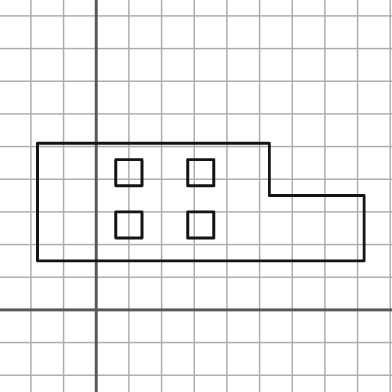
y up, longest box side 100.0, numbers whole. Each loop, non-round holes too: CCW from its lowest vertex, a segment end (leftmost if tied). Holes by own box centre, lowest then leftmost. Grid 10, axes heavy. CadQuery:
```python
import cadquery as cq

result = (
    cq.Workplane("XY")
    .moveTo(-18.0, 15.0)
    .lineTo(82.0, 15.0)
    .lineTo(82.0, 35.0)
    .lineTo(53.0, 35.0)
    .lineTo(53.0, 51.0)
    .lineTo(-18.0, 51.0)
    .close()
    .moveTo(6.0, 22.0)
    .lineTo(14.0, 22.0)
    .lineTo(14.0, 30.0)
    .lineTo(6.0, 30.0)
    .close()
    .moveTo(28.0, 22.0)
    .lineTo(36.0, 22.0)
    .lineTo(36.0, 30.0)
    .lineTo(28.0, 30.0)
    .close()
    .moveTo(6.0, 38.0)
    .lineTo(14.0, 38.0)
    .lineTo(14.0, 46.0)
    .lineTo(6.0, 46.0)
    .close()
    .moveTo(28.0, 38.0)
    .lineTo(36.0, 38.0)
    .lineTo(36.0, 46.0)
    .lineTo(28.0, 46.0)
    .close()
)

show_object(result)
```